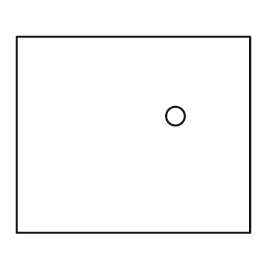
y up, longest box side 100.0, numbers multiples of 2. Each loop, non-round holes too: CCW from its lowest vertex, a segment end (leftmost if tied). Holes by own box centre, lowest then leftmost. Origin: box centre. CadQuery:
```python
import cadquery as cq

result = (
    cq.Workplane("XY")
    .moveTo(-50.0, -42.0)
    .lineTo(50.0, -42.0)
    .lineTo(50.0, 42.0)
    .lineTo(-50.0, 42.0)
    .close()
    .moveTo(18.0, 8.0)
    .circle(4.0)
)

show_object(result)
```